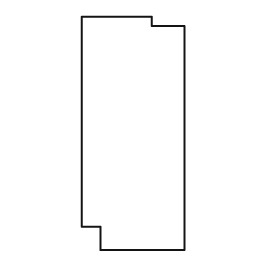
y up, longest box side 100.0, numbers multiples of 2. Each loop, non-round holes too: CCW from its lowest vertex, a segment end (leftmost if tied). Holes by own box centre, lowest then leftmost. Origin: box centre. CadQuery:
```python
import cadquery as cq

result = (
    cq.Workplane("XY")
    .moveTo(-14.0, -50.0)
    .lineTo(22.0, -50.0)
    .lineTo(22.0, 46.0)
    .lineTo(8.0, 46.0)
    .lineTo(8.0, 50.0)
    .lineTo(-22.0, 50.0)
    .lineTo(-22.0, -40.0)
    .lineTo(-14.0, -40.0)
    .close()
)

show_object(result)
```